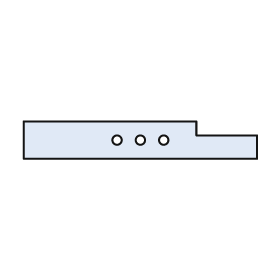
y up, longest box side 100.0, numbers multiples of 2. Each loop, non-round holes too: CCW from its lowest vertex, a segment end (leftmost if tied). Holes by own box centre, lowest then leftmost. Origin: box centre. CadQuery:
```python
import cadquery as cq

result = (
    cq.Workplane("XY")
    .moveTo(-50.0, -8.0)
    .lineTo(50.0, -8.0)
    .lineTo(50.0, 2.0)
    .lineTo(24.0, 2.0)
    .lineTo(24.0, 8.0)
    .lineTo(-50.0, 8.0)
    .close()
    .moveTo(-10.0, 0.0)
    .circle(2.0)
    .moveTo(0.0, 0.0)
    .circle(2.0)
    .moveTo(10.0, 0.0)
    .circle(2.0)
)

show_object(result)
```